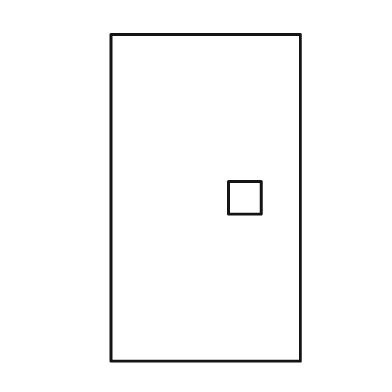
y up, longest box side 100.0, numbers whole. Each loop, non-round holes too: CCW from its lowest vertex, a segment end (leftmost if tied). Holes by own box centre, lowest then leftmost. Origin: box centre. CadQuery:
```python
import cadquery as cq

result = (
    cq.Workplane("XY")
    .moveTo(-29.0, -50.0)
    .lineTo(29.0, -50.0)
    .lineTo(29.0, 50.0)
    .lineTo(-29.0, 50.0)
    .close()
    .moveTo(7.0, -5.0)
    .lineTo(17.0, -5.0)
    .lineTo(17.0, 5.0)
    .lineTo(7.0, 5.0)
    .close()
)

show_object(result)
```